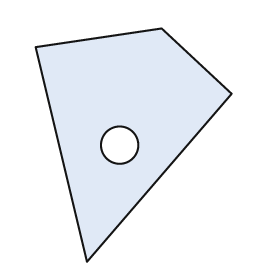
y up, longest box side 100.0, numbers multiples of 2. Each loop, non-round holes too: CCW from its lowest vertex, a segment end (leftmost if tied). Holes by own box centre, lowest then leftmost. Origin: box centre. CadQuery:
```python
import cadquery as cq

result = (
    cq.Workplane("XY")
    .moveTo(-20.0, -50.0)
    .lineTo(42.0, 22.0)
    .lineTo(12.0, 50.0)
    .lineTo(-42.0, 42.0)
    .close()
    .moveTo(-6.0, 0.0)
    .circle(8.0)
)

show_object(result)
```